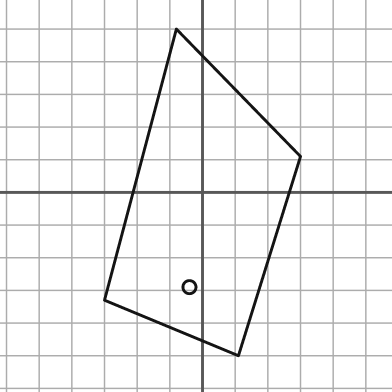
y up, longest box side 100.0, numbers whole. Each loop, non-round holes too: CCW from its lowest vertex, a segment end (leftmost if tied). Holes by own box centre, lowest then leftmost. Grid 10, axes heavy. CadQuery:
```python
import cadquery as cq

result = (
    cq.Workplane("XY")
    .moveTo(11.0, -50.0)
    .lineTo(30.0, 11.0)
    .lineTo(-8.0, 50.0)
    .lineTo(-30.0, -33.0)
    .close()
    .moveTo(-4.0, -29.0)
    .circle(2.0)
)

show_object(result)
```